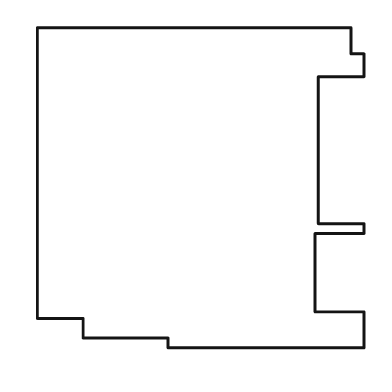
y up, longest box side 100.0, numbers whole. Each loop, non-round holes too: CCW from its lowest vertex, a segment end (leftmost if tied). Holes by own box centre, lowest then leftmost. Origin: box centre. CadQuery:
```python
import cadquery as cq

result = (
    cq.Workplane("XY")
    .moveTo(-10.0, -49.0)
    .lineTo(50.0, -49.0)
    .lineTo(50.0, -38.0)
    .lineTo(35.0, -38.0)
    .lineTo(35.0, -14.0)
    .lineTo(50.0, -14.0)
    .lineTo(50.0, -11.0)
    .lineTo(36.0, -11.0)
    .lineTo(36.0, 34.0)
    .lineTo(50.0, 34.0)
    .lineTo(50.0, 41.0)
    .lineTo(46.0, 41.0)
    .lineTo(46.0, 49.0)
    .lineTo(-50.0, 49.0)
    .lineTo(-50.0, -40.0)
    .lineTo(-36.0, -40.0)
    .lineTo(-36.0, -46.0)
    .lineTo(-10.0, -46.0)
    .close()
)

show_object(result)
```